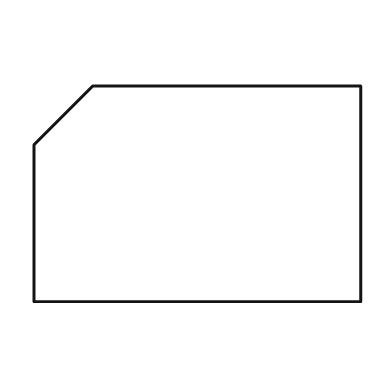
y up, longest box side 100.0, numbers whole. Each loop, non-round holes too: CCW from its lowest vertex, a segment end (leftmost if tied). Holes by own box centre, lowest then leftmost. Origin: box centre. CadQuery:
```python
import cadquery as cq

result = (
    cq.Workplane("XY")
    .moveTo(-50.0, -33.0)
    .lineTo(50.0, -33.0)
    .lineTo(50.0, 33.0)
    .lineTo(-32.0, 33.0)
    .lineTo(-50.0, 15.0)
    .close()
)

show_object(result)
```